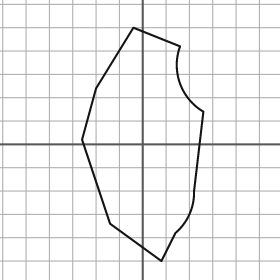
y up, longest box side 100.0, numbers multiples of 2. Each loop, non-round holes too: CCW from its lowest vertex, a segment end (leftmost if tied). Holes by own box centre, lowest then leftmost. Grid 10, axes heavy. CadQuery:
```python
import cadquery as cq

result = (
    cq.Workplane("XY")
    .moveTo(8.0, -50.0)
    .lineTo(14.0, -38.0)
    .threePointArc((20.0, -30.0), (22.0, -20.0))
    .lineTo(26.0, 14.0)
    .threePointArc((16.0, 26.0), (16.0, 42.0))
    .lineTo(-4.0, 50.0)
    .lineTo(-20.0, 24.0)
    .lineTo(-26.0, 2.0)
    .lineTo(-14.0, -34.0)
    .close()
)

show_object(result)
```